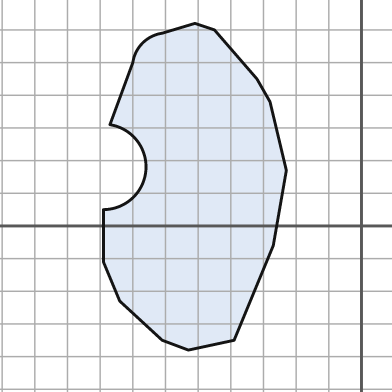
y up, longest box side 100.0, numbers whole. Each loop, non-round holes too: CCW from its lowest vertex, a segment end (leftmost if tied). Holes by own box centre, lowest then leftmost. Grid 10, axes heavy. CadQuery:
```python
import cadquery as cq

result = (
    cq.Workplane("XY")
    .moveTo(-53.0, -38.0)
    .lineTo(-39.0, -35.0)
    .lineTo(-27.0, -6.0)
    .lineTo(-23.0, 17.0)
    .lineTo(-28.0, 38.0)
    .lineTo(-32.0, 45.0)
    .lineTo(-45.0, 60.0)
    .lineTo(-51.0, 62.0)
    .lineTo(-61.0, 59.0)
    .threePointArc((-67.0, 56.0), (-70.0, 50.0))
    .lineTo(-77.0, 31.0)
    .threePointArc((-66.0, 17.0), (-79.0, 5.0))
    .lineTo(-79.0, -11.0)
    .lineTo(-74.0, -23.0)
    .lineTo(-61.0, -35.0)
    .close()
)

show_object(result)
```